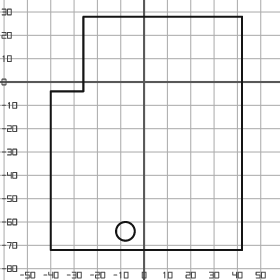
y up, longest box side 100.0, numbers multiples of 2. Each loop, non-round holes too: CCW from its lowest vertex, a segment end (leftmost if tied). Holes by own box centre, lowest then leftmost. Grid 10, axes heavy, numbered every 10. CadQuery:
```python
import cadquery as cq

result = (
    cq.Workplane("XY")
    .moveTo(-40.0, -72.0)
    .lineTo(42.0, -72.0)
    .lineTo(42.0, 28.0)
    .lineTo(-26.0, 28.0)
    .lineTo(-26.0, -4.0)
    .lineTo(-40.0, -4.0)
    .close()
    .moveTo(-8.0, -64.0)
    .circle(4.0)
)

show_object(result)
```